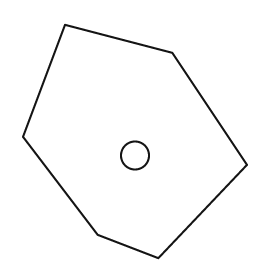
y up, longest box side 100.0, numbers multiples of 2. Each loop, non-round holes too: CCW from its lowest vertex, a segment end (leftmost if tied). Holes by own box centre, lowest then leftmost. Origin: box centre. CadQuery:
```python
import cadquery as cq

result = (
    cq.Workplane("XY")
    .moveTo(10.0, -50.0)
    .lineTo(48.0, -10.0)
    .lineTo(16.0, 38.0)
    .lineTo(-30.0, 50.0)
    .lineTo(-48.0, 2.0)
    .lineTo(-16.0, -40.0)
    .close()
    .moveTo(0.0, -6.0)
    .circle(6.0)
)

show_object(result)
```